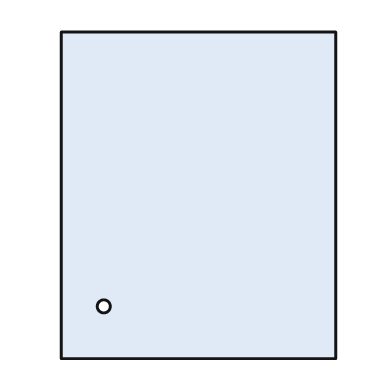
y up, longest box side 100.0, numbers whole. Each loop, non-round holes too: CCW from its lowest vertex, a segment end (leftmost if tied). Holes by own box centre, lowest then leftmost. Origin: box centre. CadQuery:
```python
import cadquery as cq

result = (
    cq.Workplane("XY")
    .moveTo(-42.0, -50.0)
    .lineTo(42.0, -50.0)
    .lineTo(42.0, 50.0)
    .lineTo(-42.0, 50.0)
    .close()
    .moveTo(-29.0, -34.0)
    .circle(2.0)
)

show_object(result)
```